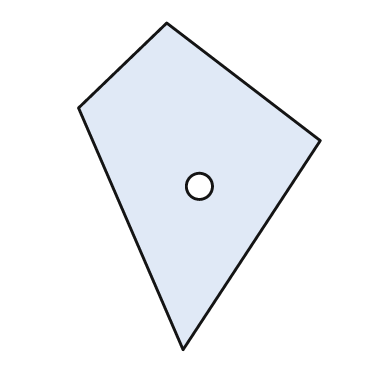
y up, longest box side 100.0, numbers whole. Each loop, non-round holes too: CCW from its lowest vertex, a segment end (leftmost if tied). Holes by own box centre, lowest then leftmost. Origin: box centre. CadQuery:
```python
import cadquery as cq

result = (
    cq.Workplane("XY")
    .moveTo(-5.0, -50.0)
    .lineTo(37.0, 14.0)
    .lineTo(-10.0, 50.0)
    .lineTo(-37.0, 24.0)
    .close()
    .moveTo(0.0, 0.0)
    .circle(4.0)
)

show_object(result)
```